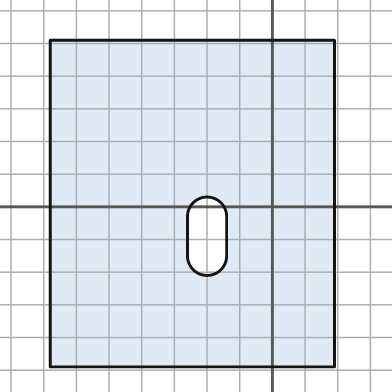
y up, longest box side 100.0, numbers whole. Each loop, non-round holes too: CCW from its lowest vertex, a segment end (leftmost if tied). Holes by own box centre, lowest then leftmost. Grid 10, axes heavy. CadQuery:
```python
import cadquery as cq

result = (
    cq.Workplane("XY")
    .moveTo(-68.0, -49.0)
    .lineTo(19.0, -49.0)
    .lineTo(19.0, 51.0)
    .lineTo(-68.0, 51.0)
    .close()
    .moveTo(-26.0, -15.0)
    .threePointArc((-20.0, -21.0), (-14.0, -15.0))
    .lineTo(-14.0, -3.0)
    .threePointArc((-20.0, 3.0), (-26.0, -3.0))
    .close()
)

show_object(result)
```